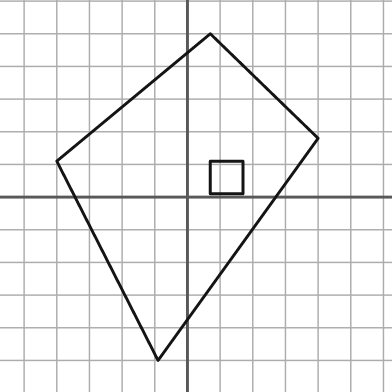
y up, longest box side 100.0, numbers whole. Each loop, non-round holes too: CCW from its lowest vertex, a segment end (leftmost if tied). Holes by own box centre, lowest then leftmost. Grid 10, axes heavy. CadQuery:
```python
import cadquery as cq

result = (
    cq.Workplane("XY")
    .moveTo(-9.0, -50.0)
    .lineTo(40.0, 18.0)
    .lineTo(7.0, 50.0)
    .lineTo(-40.0, 11.0)
    .close()
    .moveTo(7.0, 1.0)
    .lineTo(17.0, 1.0)
    .lineTo(17.0, 11.0)
    .lineTo(7.0, 11.0)
    .close()
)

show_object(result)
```